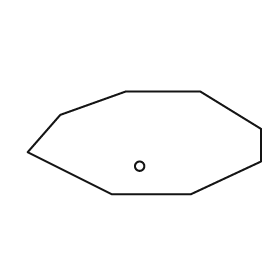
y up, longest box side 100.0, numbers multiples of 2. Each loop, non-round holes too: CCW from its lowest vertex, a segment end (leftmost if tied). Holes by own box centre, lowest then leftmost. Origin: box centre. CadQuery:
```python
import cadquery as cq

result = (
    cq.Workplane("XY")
    .moveTo(-14.0, -22.0)
    .lineTo(20.0, -22.0)
    .lineTo(50.0, -8.0)
    .lineTo(50.0, 6.0)
    .lineTo(24.0, 22.0)
    .lineTo(-8.0, 22.0)
    .lineTo(-36.0, 12.0)
    .lineTo(-50.0, -4.0)
    .close()
    .moveTo(-2.0, -10.0)
    .circle(2.0)
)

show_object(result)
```